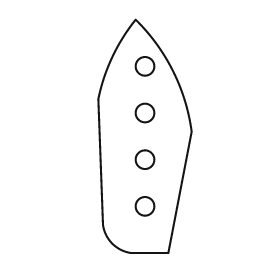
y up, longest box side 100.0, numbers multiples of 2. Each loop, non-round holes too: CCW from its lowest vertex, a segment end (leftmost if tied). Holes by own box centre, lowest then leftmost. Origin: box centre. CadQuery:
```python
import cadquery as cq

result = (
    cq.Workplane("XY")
    .moveTo(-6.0, -50.0)
    .lineTo(10.0, -50.0)
    .lineTo(20.0, 2.0)
    .threePointArc((12.0, 28.0), (-4.0, 50.0))
    .threePointArc((-14.0, 34.0), (-20.0, 16.0))
    .lineTo(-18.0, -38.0)
    .threePointArc((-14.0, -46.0), (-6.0, -50.0))
    .close()
    .moveTo(0.0, -30.0)
    .circle(4.0)
    .moveTo(0.0, -10.0)
    .circle(4.0)
    .moveTo(0.0, 10.0)
    .circle(4.0)
    .moveTo(0.0, 30.0)
    .circle(4.0)
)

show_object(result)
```